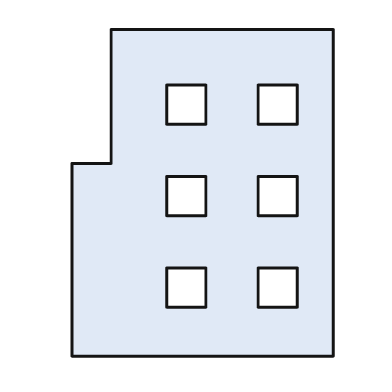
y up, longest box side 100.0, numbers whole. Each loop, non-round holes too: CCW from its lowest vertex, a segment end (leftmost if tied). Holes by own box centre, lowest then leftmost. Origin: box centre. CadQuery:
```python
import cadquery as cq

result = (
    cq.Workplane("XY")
    .moveTo(-40.0, -50.0)
    .lineTo(40.0, -50.0)
    .lineTo(40.0, 50.0)
    .lineTo(-28.0, 50.0)
    .lineTo(-28.0, 9.0)
    .lineTo(-40.0, 9.0)
    .close()
    .moveTo(-11.0, -35.0)
    .lineTo(1.0, -35.0)
    .lineTo(1.0, -23.0)
    .lineTo(-11.0, -23.0)
    .close()
    .moveTo(17.0, -35.0)
    .lineTo(29.0, -35.0)
    .lineTo(29.0, -23.0)
    .lineTo(17.0, -23.0)
    .close()
    .moveTo(-11.0, -7.0)
    .lineTo(1.0, -7.0)
    .lineTo(1.0, 5.0)
    .lineTo(-11.0, 5.0)
    .close()
    .moveTo(17.0, -7.0)
    .lineTo(29.0, -7.0)
    .lineTo(29.0, 5.0)
    .lineTo(17.0, 5.0)
    .close()
    .moveTo(-11.0, 21.0)
    .lineTo(1.0, 21.0)
    .lineTo(1.0, 33.0)
    .lineTo(-11.0, 33.0)
    .close()
    .moveTo(17.0, 21.0)
    .lineTo(29.0, 21.0)
    .lineTo(29.0, 33.0)
    .lineTo(17.0, 33.0)
    .close()
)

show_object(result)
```